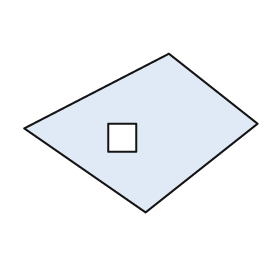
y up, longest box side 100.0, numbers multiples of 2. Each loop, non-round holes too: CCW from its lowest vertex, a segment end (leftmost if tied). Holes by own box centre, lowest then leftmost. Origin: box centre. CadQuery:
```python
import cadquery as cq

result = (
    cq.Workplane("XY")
    .moveTo(2.0, -34.0)
    .lineTo(50.0, 4.0)
    .lineTo(12.0, 34.0)
    .lineTo(-50.0, 2.0)
    .close()
    .moveTo(-14.0, -8.0)
    .lineTo(-2.0, -8.0)
    .lineTo(-2.0, 4.0)
    .lineTo(-14.0, 4.0)
    .close()
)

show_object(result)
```